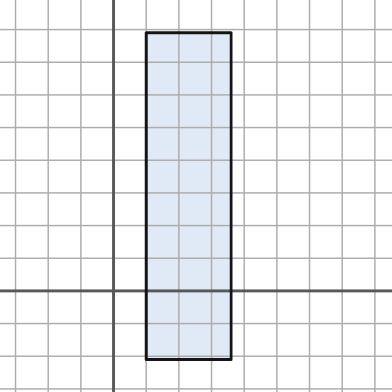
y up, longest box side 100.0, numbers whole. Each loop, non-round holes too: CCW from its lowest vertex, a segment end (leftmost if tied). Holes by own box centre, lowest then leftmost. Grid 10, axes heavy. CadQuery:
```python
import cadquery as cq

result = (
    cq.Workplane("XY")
    .moveTo(10.0, -21.0)
    .lineTo(36.0, -21.0)
    .lineTo(36.0, 79.0)
    .lineTo(10.0, 79.0)
    .close()
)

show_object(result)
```